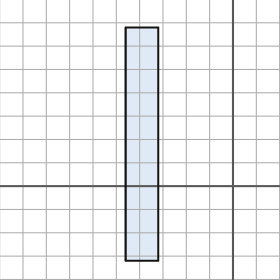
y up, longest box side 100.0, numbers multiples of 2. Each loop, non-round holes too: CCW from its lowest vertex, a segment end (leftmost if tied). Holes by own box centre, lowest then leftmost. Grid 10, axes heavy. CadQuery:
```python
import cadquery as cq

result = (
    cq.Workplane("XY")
    .moveTo(-46.0, -32.0)
    .lineTo(-32.0, -32.0)
    .lineTo(-32.0, 68.0)
    .lineTo(-46.0, 68.0)
    .close()
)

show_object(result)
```